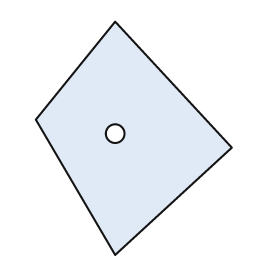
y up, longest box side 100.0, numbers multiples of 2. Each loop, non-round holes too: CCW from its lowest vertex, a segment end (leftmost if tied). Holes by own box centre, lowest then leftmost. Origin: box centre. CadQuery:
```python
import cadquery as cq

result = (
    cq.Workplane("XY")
    .moveTo(-8.0, -50.0)
    .lineTo(42.0, -4.0)
    .lineTo(-8.0, 50.0)
    .lineTo(-42.0, 8.0)
    .close()
    .moveTo(-8.0, 2.0)
    .circle(4.0)
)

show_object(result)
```